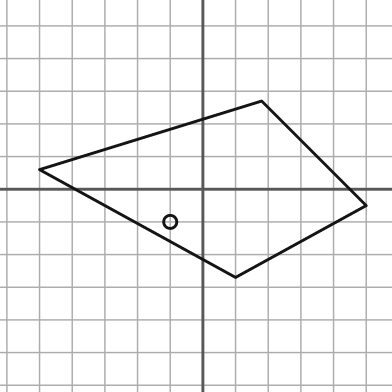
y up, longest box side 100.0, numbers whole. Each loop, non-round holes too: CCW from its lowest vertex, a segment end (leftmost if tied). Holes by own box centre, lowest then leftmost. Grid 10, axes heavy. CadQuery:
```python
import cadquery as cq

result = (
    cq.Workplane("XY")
    .moveTo(10.0, -27.0)
    .lineTo(50.0, -5.0)
    .lineTo(18.0, 27.0)
    .lineTo(-50.0, 6.0)
    .close()
    .moveTo(-10.0, -10.0)
    .circle(2.0)
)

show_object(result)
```